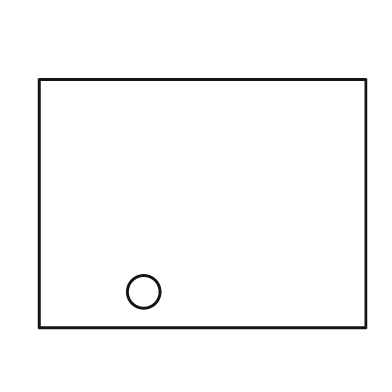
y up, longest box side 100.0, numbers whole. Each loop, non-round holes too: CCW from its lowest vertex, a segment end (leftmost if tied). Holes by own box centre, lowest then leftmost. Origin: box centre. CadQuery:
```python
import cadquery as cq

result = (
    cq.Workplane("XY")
    .moveTo(-50.0, -38.0)
    .lineTo(50.0, -38.0)
    .lineTo(50.0, 38.0)
    .lineTo(-50.0, 38.0)
    .close()
    .moveTo(-18.0, -27.0)
    .circle(5.0)
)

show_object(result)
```